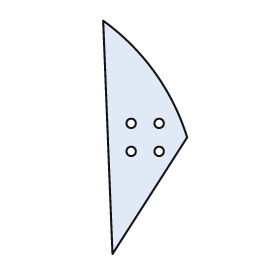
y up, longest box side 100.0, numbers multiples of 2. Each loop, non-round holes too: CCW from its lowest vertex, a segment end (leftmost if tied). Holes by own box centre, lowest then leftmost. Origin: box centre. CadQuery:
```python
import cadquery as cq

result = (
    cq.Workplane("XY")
    .moveTo(-14.0, -50.0)
    .lineTo(18.0, 0.0)
    .threePointArc((4.0, 28.0), (-18.0, 50.0))
    .close()
    .moveTo(-6.0, -6.0)
    .circle(2.0)
    .moveTo(6.0, -6.0)
    .circle(2.0)
    .moveTo(-6.0, 6.0)
    .circle(2.0)
    .moveTo(6.0, 6.0)
    .circle(2.0)
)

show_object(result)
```